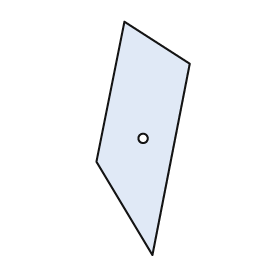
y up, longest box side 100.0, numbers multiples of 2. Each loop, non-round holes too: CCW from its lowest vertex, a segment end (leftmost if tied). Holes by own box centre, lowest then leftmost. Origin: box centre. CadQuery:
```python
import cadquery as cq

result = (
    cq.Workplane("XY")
    .moveTo(4.0, -50.0)
    .lineTo(20.0, 32.0)
    .lineTo(-8.0, 50.0)
    .lineTo(-20.0, -10.0)
    .close()
    .moveTo(0.0, 0.0)
    .circle(2.0)
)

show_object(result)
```